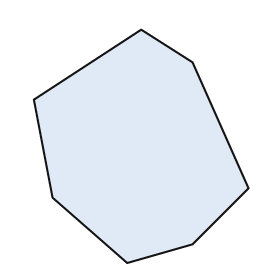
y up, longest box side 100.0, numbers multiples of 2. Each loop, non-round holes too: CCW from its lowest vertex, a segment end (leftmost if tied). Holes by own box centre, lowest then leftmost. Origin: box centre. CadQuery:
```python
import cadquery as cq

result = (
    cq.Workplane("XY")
    .moveTo(-6.0, -50.0)
    .lineTo(22.0, -42.0)
    .lineTo(46.0, -18.0)
    .lineTo(22.0, 36.0)
    .lineTo(0.0, 50.0)
    .lineTo(-46.0, 20.0)
    .lineTo(-38.0, -22.0)
    .close()
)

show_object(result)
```